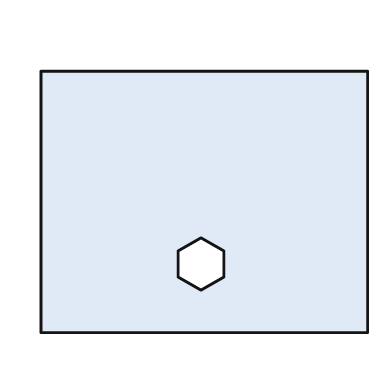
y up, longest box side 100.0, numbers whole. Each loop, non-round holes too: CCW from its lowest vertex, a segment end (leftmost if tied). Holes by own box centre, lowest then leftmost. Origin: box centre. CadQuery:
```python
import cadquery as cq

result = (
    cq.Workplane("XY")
    .moveTo(-50.0, -40.0)
    .lineTo(50.0, -40.0)
    .lineTo(50.0, 40.0)
    .lineTo(-50.0, 40.0)
    .close()
    .moveTo(-1.0, -27.0)
    .lineTo(6.0, -23.0)
    .lineTo(6.0, -15.0)
    .lineTo(-1.0, -11.0)
    .lineTo(-8.0, -15.0)
    .lineTo(-8.0, -23.0)
    .close()
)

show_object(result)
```